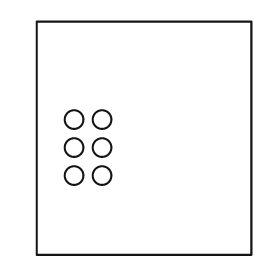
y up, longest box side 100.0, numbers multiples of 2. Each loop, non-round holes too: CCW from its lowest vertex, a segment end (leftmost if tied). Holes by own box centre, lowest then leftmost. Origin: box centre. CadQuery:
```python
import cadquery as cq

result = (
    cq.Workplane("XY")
    .moveTo(-46.0, -50.0)
    .lineTo(46.0, -50.0)
    .lineTo(46.0, 50.0)
    .lineTo(-46.0, 50.0)
    .close()
    .moveTo(-30.0, -16.0)
    .circle(4.0)
    .moveTo(-18.0, -16.0)
    .circle(4.0)
    .moveTo(-30.0, -4.0)
    .circle(4.0)
    .moveTo(-18.0, -4.0)
    .circle(4.0)
    .moveTo(-30.0, 8.0)
    .circle(4.0)
    .moveTo(-18.0, 8.0)
    .circle(4.0)
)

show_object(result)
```